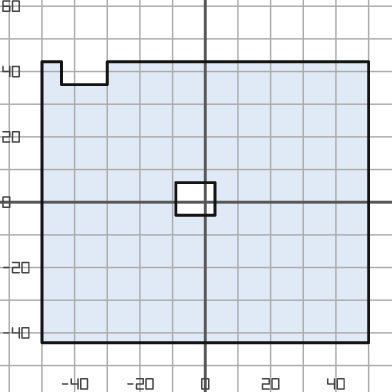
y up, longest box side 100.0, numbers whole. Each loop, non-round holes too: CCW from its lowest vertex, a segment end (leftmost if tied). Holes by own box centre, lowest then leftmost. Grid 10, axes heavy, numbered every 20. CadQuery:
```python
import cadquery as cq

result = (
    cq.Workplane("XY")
    .moveTo(-50.0, -43.0)
    .lineTo(50.0, -43.0)
    .lineTo(50.0, 43.0)
    .lineTo(-30.0, 43.0)
    .lineTo(-30.0, 36.0)
    .lineTo(-44.0, 36.0)
    .lineTo(-44.0, 43.0)
    .lineTo(-50.0, 43.0)
    .close()
    .moveTo(-9.0, -4.0)
    .lineTo(3.0, -4.0)
    .lineTo(3.0, 6.0)
    .lineTo(-9.0, 6.0)
    .close()
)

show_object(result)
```